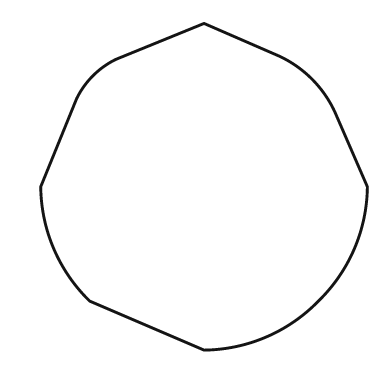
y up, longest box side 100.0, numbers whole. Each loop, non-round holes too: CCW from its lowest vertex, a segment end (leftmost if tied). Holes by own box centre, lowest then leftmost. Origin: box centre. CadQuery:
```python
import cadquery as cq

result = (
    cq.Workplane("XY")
    .moveTo(0.0, -50.0)
    .threePointArc((19.0, -46.0), (35.0, -35.0))
    .threePointArc((46.0, -19.0), (50.0, 0.0))
    .lineTo(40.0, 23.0)
    .threePointArc((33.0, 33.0), (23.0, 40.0))
    .lineTo(0.0, 50.0)
    .lineTo(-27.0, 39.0)
    .threePointArc((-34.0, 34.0), (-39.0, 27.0))
    .lineTo(-50.0, 0.0)
    .threePointArc((-46.0, -19.0), (-35.0, -35.0))
    .close()
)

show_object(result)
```